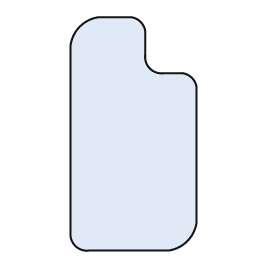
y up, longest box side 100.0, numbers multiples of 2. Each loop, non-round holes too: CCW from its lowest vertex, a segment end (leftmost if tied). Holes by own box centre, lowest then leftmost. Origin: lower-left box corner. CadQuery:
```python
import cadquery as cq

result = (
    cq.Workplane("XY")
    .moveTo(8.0, 0.0)
    .lineTo(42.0, 0.0)
    .threePointArc((50.0, 4.0), (54.0, 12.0))
    .lineTo(54.0, 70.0)
    .threePointArc((52.0, 74.0), (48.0, 76.0))
    .lineTo(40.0, 76.0)
    .threePointArc((34.0, 78.0), (32.0, 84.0))
    .lineTo(32.0, 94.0)
    .threePointArc((30.0, 98.0), (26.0, 100.0))
    .lineTo(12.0, 100.0)
    .threePointArc((4.0, 96.0), (0.0, 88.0))
    .lineTo(0.0, 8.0)
    .threePointArc((2.0, 2.0), (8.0, 0.0))
    .close()
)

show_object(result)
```